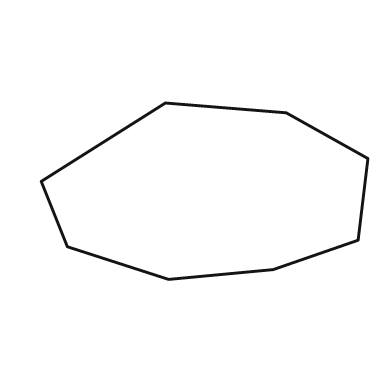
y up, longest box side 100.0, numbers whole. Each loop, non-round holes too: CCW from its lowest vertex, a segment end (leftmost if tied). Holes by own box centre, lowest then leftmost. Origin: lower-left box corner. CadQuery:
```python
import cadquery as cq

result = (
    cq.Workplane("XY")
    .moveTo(39.0, 0.0)
    .lineTo(71.0, 3.0)
    .lineTo(97.0, 12.0)
    .lineTo(100.0, 37.0)
    .lineTo(75.0, 51.0)
    .lineTo(38.0, 54.0)
    .lineTo(0.0, 30.0)
    .lineTo(8.0, 10.0)
    .close()
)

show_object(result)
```